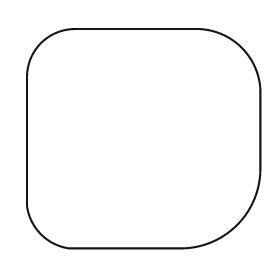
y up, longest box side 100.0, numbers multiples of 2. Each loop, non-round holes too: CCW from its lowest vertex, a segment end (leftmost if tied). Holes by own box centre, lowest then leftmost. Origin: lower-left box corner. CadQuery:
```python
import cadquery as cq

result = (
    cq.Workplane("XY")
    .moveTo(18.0, 0.0)
    .lineTo(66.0, 0.0)
    .threePointArc((90.0, 10.0), (100.0, 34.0))
    .lineTo(100.0, 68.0)
    .threePointArc((92.0, 86.0), (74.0, 94.0))
    .lineTo(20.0, 94.0)
    .threePointArc((6.0, 88.0), (0.0, 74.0))
    .lineTo(0.0, 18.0)
    .threePointArc((6.0, 6.0), (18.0, 0.0))
    .close()
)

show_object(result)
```